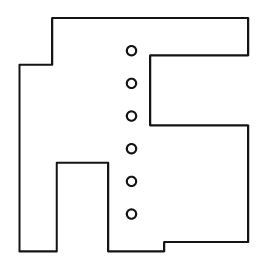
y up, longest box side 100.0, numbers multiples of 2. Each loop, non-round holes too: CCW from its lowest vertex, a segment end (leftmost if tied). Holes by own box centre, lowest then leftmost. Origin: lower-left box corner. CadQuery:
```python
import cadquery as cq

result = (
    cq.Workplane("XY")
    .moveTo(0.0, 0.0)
    .lineTo(16.0, 0.0)
    .lineTo(16.0, 38.0)
    .lineTo(38.0, 38.0)
    .lineTo(38.0, 0.0)
    .lineTo(62.0, 0.0)
    .lineTo(62.0, 4.0)
    .lineTo(98.0, 4.0)
    .lineTo(98.0, 54.0)
    .lineTo(56.0, 54.0)
    .lineTo(56.0, 84.0)
    .lineTo(98.0, 84.0)
    .lineTo(98.0, 100.0)
    .lineTo(14.0, 100.0)
    .lineTo(14.0, 80.0)
    .lineTo(0.0, 80.0)
    .close()
    .moveTo(48.0, 16.0)
    .circle(2.0)
    .moveTo(48.0, 30.0)
    .circle(2.0)
    .moveTo(48.0, 44.0)
    .circle(2.0)
    .moveTo(48.0, 58.0)
    .circle(2.0)
    .moveTo(48.0, 72.0)
    .circle(2.0)
    .moveTo(48.0, 86.0)
    .circle(2.0)
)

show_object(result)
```